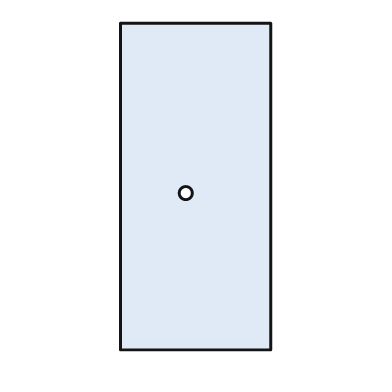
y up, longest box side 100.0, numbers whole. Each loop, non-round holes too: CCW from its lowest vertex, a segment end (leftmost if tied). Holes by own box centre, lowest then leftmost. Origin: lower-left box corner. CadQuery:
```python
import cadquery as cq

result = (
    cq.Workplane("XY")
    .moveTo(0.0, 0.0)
    .lineTo(46.0, 0.0)
    .lineTo(46.0, 100.0)
    .lineTo(0.0, 100.0)
    .close()
    .moveTo(20.0, 48.0)
    .circle(2.0)
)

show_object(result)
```